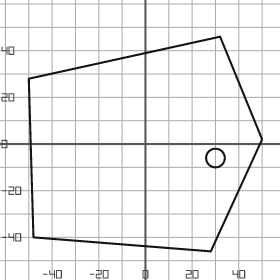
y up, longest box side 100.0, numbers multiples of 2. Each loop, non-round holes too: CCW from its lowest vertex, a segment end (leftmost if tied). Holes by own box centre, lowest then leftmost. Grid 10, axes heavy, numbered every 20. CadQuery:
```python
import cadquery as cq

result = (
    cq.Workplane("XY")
    .moveTo(28.0, -46.0)
    .lineTo(50.0, 2.0)
    .lineTo(32.0, 46.0)
    .lineTo(-50.0, 28.0)
    .lineTo(-48.0, -40.0)
    .close()
    .moveTo(30.0, -6.0)
    .circle(4.0)
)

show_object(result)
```